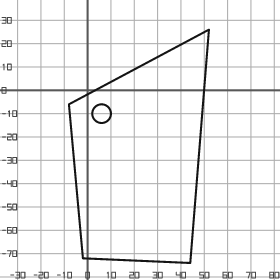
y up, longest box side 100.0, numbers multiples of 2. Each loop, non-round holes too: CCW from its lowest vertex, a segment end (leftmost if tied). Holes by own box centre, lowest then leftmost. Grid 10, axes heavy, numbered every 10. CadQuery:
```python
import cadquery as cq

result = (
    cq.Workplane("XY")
    .moveTo(44.0, -74.0)
    .lineTo(52.0, 26.0)
    .lineTo(-8.0, -6.0)
    .lineTo(-2.0, -72.0)
    .close()
    .moveTo(6.0, -10.0)
    .circle(4.0)
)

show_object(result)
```